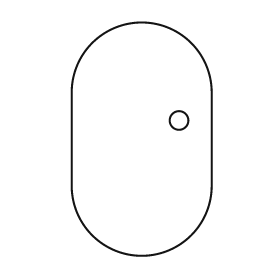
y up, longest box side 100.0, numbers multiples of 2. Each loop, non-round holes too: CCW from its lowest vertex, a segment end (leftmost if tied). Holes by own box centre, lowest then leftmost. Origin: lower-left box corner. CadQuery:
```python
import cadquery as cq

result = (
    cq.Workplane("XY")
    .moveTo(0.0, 30.0)
    .threePointArc((30.0, 0.0), (60.0, 30.0))
    .lineTo(60.0, 70.0)
    .threePointArc((30.0, 100.0), (0.0, 70.0))
    .close()
    .moveTo(46.0, 58.0)
    .circle(4.0)
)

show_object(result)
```